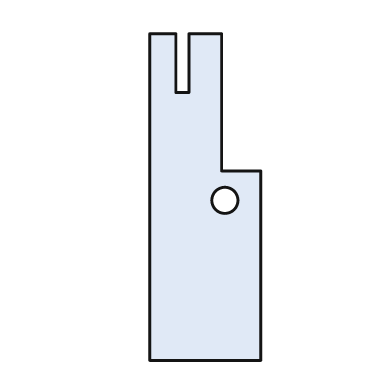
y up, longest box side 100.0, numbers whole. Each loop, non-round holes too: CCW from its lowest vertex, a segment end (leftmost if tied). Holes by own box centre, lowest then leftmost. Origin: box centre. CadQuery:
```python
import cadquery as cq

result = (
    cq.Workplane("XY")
    .moveTo(-17.0, -50.0)
    .lineTo(17.0, -50.0)
    .lineTo(17.0, 8.0)
    .lineTo(5.0, 8.0)
    .lineTo(5.0, 50.0)
    .lineTo(-5.0, 50.0)
    .lineTo(-5.0, 32.0)
    .lineTo(-9.0, 32.0)
    .lineTo(-9.0, 50.0)
    .lineTo(-17.0, 50.0)
    .close()
    .moveTo(6.0, -1.0)
    .circle(4.0)
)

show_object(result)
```